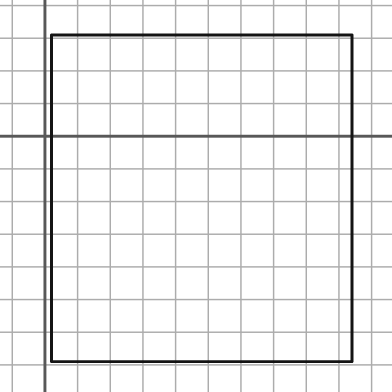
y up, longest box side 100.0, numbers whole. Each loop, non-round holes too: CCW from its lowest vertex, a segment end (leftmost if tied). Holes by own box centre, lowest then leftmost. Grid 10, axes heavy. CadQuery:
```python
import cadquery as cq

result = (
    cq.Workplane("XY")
    .moveTo(2.0, -69.0)
    .lineTo(94.0, -69.0)
    .lineTo(94.0, 31.0)
    .lineTo(2.0, 31.0)
    .close()
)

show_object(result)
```